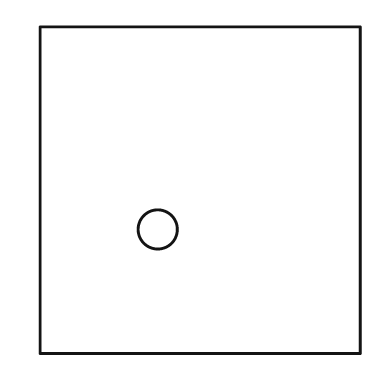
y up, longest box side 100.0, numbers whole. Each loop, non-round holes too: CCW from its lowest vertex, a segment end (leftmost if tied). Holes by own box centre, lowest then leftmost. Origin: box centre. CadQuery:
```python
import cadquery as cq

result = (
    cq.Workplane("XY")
    .moveTo(-49.0, -50.0)
    .lineTo(49.0, -50.0)
    .lineTo(49.0, 50.0)
    .lineTo(-49.0, 50.0)
    .close()
    .moveTo(-13.0, -12.0)
    .circle(6.0)
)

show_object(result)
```